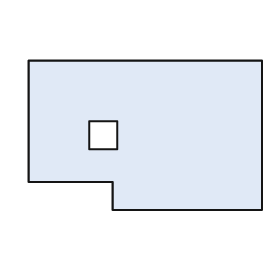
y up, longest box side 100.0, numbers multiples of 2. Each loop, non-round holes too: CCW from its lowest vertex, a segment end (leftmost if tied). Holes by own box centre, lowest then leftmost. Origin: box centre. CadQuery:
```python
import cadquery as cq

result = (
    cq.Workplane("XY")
    .moveTo(-14.0, -32.0)
    .lineTo(50.0, -32.0)
    .lineTo(50.0, 32.0)
    .lineTo(-50.0, 32.0)
    .lineTo(-50.0, -20.0)
    .lineTo(-14.0, -20.0)
    .close()
    .moveTo(-24.0, -6.0)
    .lineTo(-12.0, -6.0)
    .lineTo(-12.0, 6.0)
    .lineTo(-24.0, 6.0)
    .close()
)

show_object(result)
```